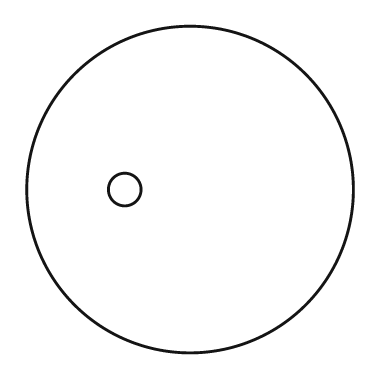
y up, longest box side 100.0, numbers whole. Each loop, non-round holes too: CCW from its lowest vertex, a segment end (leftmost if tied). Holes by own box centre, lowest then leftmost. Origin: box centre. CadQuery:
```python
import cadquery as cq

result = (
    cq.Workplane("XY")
    .moveTo(0.0, 0.0)
    .circle(50.0)
    .moveTo(-20.0, 0.0)
    .circle(5.0)
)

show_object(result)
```